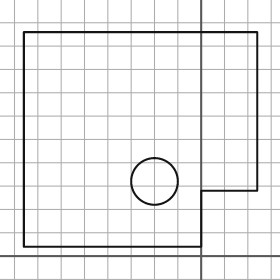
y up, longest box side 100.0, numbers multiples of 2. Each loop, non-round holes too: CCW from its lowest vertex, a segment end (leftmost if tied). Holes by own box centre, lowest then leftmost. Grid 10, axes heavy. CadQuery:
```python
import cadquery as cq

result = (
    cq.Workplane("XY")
    .moveTo(-76.0, 4.0)
    .lineTo(0.0, 4.0)
    .lineTo(0.0, 28.0)
    .lineTo(24.0, 28.0)
    .lineTo(24.0, 96.0)
    .lineTo(-76.0, 96.0)
    .close()
    .moveTo(-20.0, 32.0)
    .circle(10.0)
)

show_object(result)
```